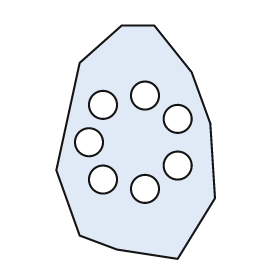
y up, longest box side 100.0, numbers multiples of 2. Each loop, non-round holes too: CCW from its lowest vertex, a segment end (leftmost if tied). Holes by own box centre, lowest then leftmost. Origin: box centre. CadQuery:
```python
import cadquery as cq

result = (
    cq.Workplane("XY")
    .moveTo(18.0, -50.0)
    .lineTo(34.0, -24.0)
    .lineTo(32.0, 8.0)
    .lineTo(24.0, 30.0)
    .lineTo(8.0, 50.0)
    .lineTo(-6.0, 50.0)
    .lineTo(-24.0, 34.0)
    .lineTo(-34.0, -12.0)
    .lineTo(-24.0, -40.0)
    .lineTo(-8.0, -46.0)
    .close()
    .moveTo(4.0, -20.0)
    .circle(6.0)
    .moveTo(-14.0, -16.0)
    .circle(6.0)
    .moveTo(18.0, -10.0)
    .circle(6.0)
    .moveTo(-20.0, 0.0)
    .circle(6.0)
    .moveTo(18.0, 10.0)
    .circle(6.0)
    .moveTo(-14.0, 16.0)
    .circle(6.0)
    .moveTo(4.0, 20.0)
    .circle(6.0)
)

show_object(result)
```